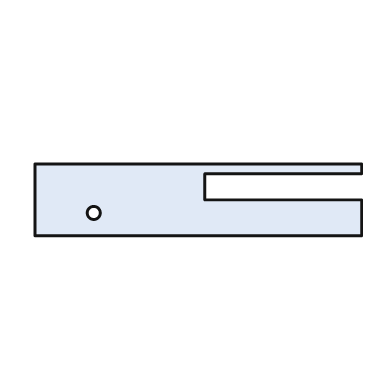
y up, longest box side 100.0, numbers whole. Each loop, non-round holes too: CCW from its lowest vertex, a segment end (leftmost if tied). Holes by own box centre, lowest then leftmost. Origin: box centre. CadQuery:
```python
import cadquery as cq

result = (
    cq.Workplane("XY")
    .moveTo(-50.0, -11.0)
    .lineTo(50.0, -11.0)
    .lineTo(50.0, 0.0)
    .lineTo(2.0, 0.0)
    .lineTo(2.0, 8.0)
    .lineTo(50.0, 8.0)
    .lineTo(50.0, 11.0)
    .lineTo(-50.0, 11.0)
    .close()
    .moveTo(-32.0, -4.0)
    .circle(2.0)
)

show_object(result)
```